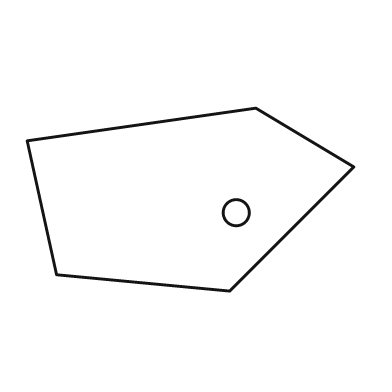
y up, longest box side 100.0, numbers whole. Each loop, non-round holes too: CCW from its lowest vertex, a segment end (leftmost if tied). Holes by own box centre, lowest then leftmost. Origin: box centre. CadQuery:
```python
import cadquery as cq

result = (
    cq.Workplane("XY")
    .moveTo(12.0, -28.0)
    .lineTo(50.0, 10.0)
    .lineTo(20.0, 28.0)
    .lineTo(-50.0, 18.0)
    .lineTo(-41.0, -23.0)
    .close()
    .moveTo(14.0, -4.0)
    .circle(4.0)
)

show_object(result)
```